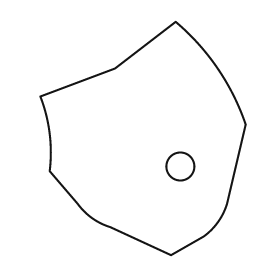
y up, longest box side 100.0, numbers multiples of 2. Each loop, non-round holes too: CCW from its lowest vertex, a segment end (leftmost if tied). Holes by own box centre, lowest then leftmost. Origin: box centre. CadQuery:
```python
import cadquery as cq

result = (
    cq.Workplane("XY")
    .moveTo(12.0, -50.0)
    .lineTo(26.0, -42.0)
    .threePointArc((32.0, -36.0), (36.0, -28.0))
    .lineTo(44.0, 6.0)
    .threePointArc((32.0, 30.0), (14.0, 50.0))
    .lineTo(-12.0, 30.0)
    .lineTo(-44.0, 18.0)
    .threePointArc((-40.0, 2.0), (-40.0, -14.0))
    .lineTo(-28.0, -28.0)
    .threePointArc((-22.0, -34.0), (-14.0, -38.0))
    .close()
    .moveTo(16.0, -12.0)
    .circle(6.0)
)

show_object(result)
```